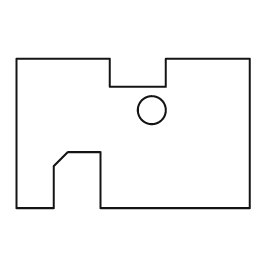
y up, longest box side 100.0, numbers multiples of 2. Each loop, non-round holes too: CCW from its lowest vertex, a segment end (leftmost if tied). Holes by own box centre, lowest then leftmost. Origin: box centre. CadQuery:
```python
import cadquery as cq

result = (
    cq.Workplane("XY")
    .moveTo(-50.0, -32.0)
    .lineTo(-34.0, -32.0)
    .lineTo(-34.0, -14.0)
    .lineTo(-28.0, -8.0)
    .lineTo(-14.0, -8.0)
    .lineTo(-14.0, -32.0)
    .lineTo(50.0, -32.0)
    .lineTo(50.0, 32.0)
    .lineTo(14.0, 32.0)
    .lineTo(14.0, 20.0)
    .lineTo(-10.0, 20.0)
    .lineTo(-10.0, 32.0)
    .lineTo(-50.0, 32.0)
    .close()
    .moveTo(8.0, 10.0)
    .circle(6.0)
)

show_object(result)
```